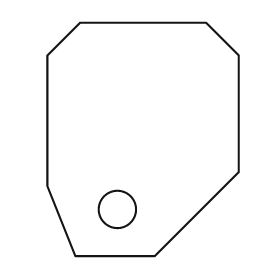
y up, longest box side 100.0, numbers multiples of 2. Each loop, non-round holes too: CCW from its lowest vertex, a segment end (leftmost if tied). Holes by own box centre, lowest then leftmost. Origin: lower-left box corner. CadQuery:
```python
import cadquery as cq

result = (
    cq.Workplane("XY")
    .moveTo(12.0, 0.0)
    .lineTo(46.0, 0.0)
    .lineTo(82.0, 36.0)
    .lineTo(82.0, 86.0)
    .lineTo(68.0, 100.0)
    .lineTo(14.0, 100.0)
    .lineTo(0.0, 86.0)
    .lineTo(0.0, 30.0)
    .close()
    .moveTo(30.0, 20.0)
    .circle(8.0)
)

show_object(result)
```